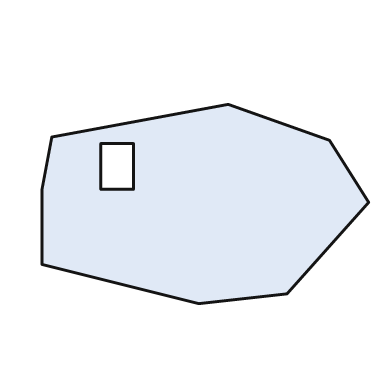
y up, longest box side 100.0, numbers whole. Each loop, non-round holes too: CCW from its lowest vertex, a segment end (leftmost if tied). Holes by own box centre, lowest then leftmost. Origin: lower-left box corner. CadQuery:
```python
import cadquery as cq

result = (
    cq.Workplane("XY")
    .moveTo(48.0, 0.0)
    .lineTo(75.0, 3.0)
    .lineTo(100.0, 31.0)
    .lineTo(88.0, 50.0)
    .lineTo(57.0, 61.0)
    .lineTo(3.0, 51.0)
    .lineTo(0.0, 35.0)
    .lineTo(0.0, 12.0)
    .close()
    .moveTo(18.0, 35.0)
    .lineTo(28.0, 35.0)
    .lineTo(28.0, 49.0)
    .lineTo(18.0, 49.0)
    .close()
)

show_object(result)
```